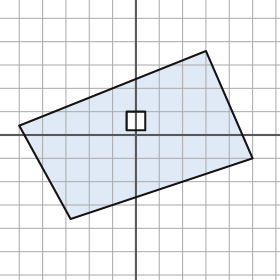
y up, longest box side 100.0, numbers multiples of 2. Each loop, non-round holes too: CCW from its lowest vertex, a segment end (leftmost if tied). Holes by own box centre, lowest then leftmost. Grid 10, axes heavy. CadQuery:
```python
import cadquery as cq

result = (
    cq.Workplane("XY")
    .moveTo(-28.0, -36.0)
    .lineTo(50.0, -10.0)
    .lineTo(30.0, 36.0)
    .lineTo(-50.0, 4.0)
    .close()
    .moveTo(-4.0, 2.0)
    .lineTo(4.0, 2.0)
    .lineTo(4.0, 10.0)
    .lineTo(-4.0, 10.0)
    .close()
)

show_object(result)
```